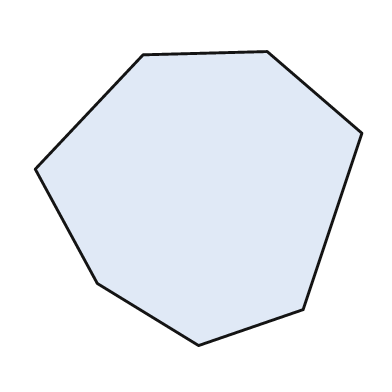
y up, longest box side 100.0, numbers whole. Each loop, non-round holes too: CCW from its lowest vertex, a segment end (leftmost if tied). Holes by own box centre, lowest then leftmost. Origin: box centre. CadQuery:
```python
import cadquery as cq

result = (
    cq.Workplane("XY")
    .moveTo(0.0, -45.0)
    .lineTo(32.0, -34.0)
    .lineTo(50.0, 20.0)
    .lineTo(21.0, 45.0)
    .lineTo(-17.0, 44.0)
    .lineTo(-50.0, 9.0)
    .lineTo(-31.0, -26.0)
    .close()
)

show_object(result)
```